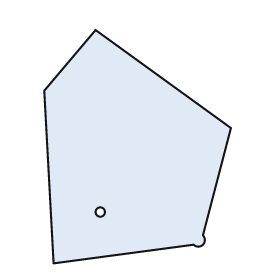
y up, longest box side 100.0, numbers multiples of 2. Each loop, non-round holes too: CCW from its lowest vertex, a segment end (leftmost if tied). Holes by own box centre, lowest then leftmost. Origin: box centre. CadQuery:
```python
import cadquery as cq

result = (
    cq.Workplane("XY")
    .moveTo(-36.0, -50.0)
    .lineTo(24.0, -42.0)
    .threePointArc((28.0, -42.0), (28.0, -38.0))
    .lineTo(40.0, 8.0)
    .lineTo(-18.0, 50.0)
    .lineTo(-40.0, 24.0)
    .close()
    .moveTo(-16.0, -28.0)
    .circle(2.0)
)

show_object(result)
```